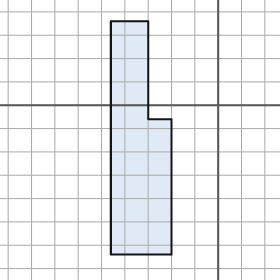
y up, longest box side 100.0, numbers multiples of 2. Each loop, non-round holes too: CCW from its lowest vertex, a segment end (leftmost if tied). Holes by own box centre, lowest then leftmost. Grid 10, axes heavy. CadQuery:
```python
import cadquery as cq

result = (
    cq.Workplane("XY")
    .moveTo(-46.0, -64.0)
    .lineTo(-20.0, -64.0)
    .lineTo(-20.0, -6.0)
    .lineTo(-30.0, -6.0)
    .lineTo(-30.0, 36.0)
    .lineTo(-46.0, 36.0)
    .close()
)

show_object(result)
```